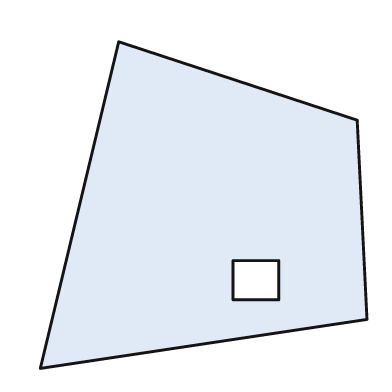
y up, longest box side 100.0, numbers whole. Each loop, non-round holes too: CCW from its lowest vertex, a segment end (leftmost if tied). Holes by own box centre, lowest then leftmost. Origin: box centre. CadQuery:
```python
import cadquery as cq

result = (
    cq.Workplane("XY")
    .moveTo(-50.0, -50.0)
    .lineTo(50.0, -35.0)
    .lineTo(47.0, 26.0)
    .lineTo(-26.0, 50.0)
    .close()
    .moveTo(9.0, -29.0)
    .lineTo(23.0, -29.0)
    .lineTo(23.0, -17.0)
    .lineTo(9.0, -17.0)
    .close()
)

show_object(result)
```